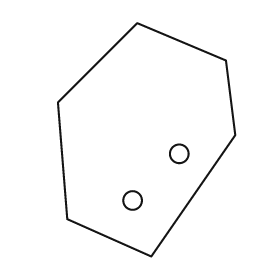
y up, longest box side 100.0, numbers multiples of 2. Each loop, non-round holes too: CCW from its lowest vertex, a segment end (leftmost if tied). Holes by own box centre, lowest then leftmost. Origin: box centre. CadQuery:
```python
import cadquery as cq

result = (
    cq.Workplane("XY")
    .moveTo(2.0, -50.0)
    .lineTo(38.0, 2.0)
    .lineTo(34.0, 34.0)
    .lineTo(-4.0, 50.0)
    .lineTo(-38.0, 16.0)
    .lineTo(-34.0, -34.0)
    .close()
    .moveTo(-6.0, -26.0)
    .circle(4.0)
    .moveTo(14.0, -6.0)
    .circle(4.0)
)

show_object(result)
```